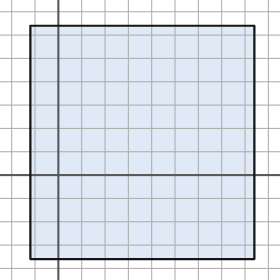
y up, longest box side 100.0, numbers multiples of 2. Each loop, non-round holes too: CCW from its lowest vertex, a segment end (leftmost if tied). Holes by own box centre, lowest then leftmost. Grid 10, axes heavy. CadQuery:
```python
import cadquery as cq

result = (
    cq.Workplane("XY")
    .moveTo(-12.0, -36.0)
    .lineTo(84.0, -36.0)
    .lineTo(84.0, 64.0)
    .lineTo(-12.0, 64.0)
    .close()
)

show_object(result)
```